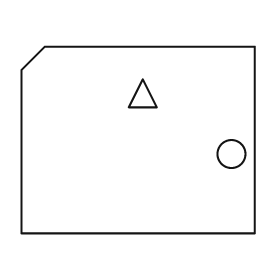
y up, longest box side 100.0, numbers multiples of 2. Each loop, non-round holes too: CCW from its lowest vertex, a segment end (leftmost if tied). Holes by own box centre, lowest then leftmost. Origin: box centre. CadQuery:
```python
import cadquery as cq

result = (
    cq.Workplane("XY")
    .moveTo(-50.0, -40.0)
    .lineTo(50.0, -40.0)
    .lineTo(50.0, 40.0)
    .lineTo(-40.0, 40.0)
    .lineTo(-50.0, 30.0)
    .close()
    .moveTo(40.0, -6.0)
    .circle(6.0)
    .moveTo(-4.0, 14.0)
    .lineTo(8.0, 14.0)
    .lineTo(2.0, 26.0)
    .close()
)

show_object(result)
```